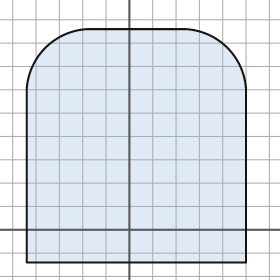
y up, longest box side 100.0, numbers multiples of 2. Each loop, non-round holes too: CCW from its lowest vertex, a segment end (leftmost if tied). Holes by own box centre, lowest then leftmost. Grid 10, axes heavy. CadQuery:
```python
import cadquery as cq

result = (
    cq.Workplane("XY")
    .moveTo(-44.0, -14.0)
    .lineTo(50.0, -14.0)
    .lineTo(50.0, 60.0)
    .threePointArc((42.0, 78.0), (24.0, 86.0))
    .lineTo(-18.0, 86.0)
    .threePointArc((-36.0, 78.0), (-44.0, 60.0))
    .close()
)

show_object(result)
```